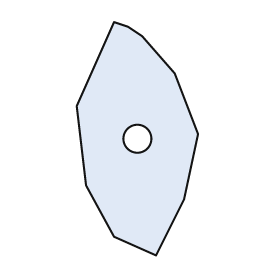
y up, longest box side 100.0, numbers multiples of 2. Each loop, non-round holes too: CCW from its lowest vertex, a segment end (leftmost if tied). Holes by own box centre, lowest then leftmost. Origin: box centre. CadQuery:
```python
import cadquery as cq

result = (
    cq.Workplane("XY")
    .moveTo(8.0, -50.0)
    .lineTo(20.0, -26.0)
    .lineTo(26.0, 2.0)
    .lineTo(16.0, 28.0)
    .lineTo(2.0, 44.0)
    .lineTo(-4.0, 48.0)
    .lineTo(-10.0, 50.0)
    .lineTo(-26.0, 14.0)
    .lineTo(-22.0, -20.0)
    .lineTo(-10.0, -42.0)
    .close()
    .moveTo(0.0, 0.0)
    .circle(6.0)
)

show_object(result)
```